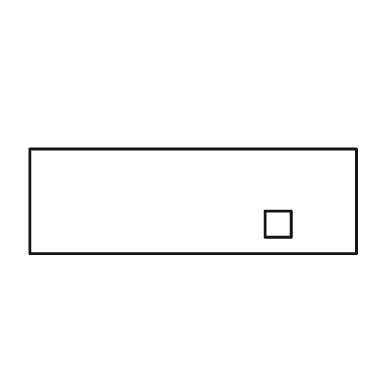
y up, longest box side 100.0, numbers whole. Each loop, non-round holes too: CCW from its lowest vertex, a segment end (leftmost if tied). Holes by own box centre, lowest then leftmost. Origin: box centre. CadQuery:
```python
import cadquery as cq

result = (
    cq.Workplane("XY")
    .moveTo(-50.0, -16.0)
    .lineTo(50.0, -16.0)
    .lineTo(50.0, 16.0)
    .lineTo(-50.0, 16.0)
    .close()
    .moveTo(22.0, -11.0)
    .lineTo(30.0, -11.0)
    .lineTo(30.0, -3.0)
    .lineTo(22.0, -3.0)
    .close()
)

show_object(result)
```